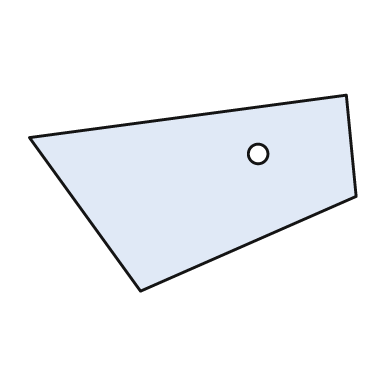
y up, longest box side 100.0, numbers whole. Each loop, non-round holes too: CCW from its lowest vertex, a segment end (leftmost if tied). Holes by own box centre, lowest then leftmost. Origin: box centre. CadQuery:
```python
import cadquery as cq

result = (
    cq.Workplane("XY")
    .moveTo(-16.0, -30.0)
    .lineTo(50.0, -1.0)
    .lineTo(47.0, 30.0)
    .lineTo(-50.0, 17.0)
    .close()
    .moveTo(20.0, 12.0)
    .circle(3.0)
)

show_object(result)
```